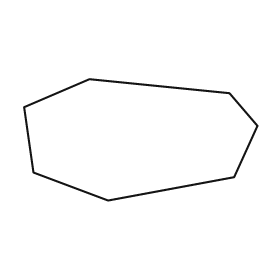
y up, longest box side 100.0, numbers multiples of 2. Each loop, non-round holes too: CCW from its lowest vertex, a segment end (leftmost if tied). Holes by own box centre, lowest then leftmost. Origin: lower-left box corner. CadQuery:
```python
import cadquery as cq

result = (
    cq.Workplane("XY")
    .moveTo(36.0, 0.0)
    .lineTo(90.0, 10.0)
    .lineTo(100.0, 32.0)
    .lineTo(88.0, 46.0)
    .lineTo(28.0, 52.0)
    .lineTo(0.0, 40.0)
    .lineTo(4.0, 12.0)
    .close()
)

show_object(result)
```